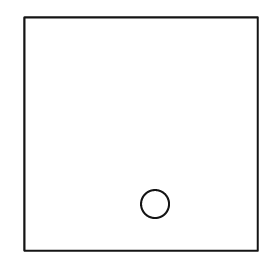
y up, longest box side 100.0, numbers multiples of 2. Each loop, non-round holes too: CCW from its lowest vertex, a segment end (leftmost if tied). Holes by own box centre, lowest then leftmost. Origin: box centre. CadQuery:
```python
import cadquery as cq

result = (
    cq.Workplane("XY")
    .moveTo(-50.0, -50.0)
    .lineTo(50.0, -50.0)
    .lineTo(50.0, 50.0)
    .lineTo(-50.0, 50.0)
    .close()
    .moveTo(6.0, -30.0)
    .circle(6.0)
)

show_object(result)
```